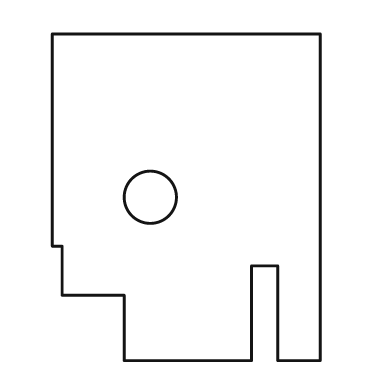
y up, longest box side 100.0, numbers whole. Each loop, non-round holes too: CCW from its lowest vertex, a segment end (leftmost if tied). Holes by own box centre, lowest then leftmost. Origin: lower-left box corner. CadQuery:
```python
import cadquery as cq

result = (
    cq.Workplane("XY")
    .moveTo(22.0, 0.0)
    .lineTo(61.0, 0.0)
    .lineTo(61.0, 29.0)
    .lineTo(69.0, 29.0)
    .lineTo(69.0, 0.0)
    .lineTo(82.0, 0.0)
    .lineTo(82.0, 100.0)
    .lineTo(0.0, 100.0)
    .lineTo(0.0, 35.0)
    .lineTo(3.0, 35.0)
    .lineTo(3.0, 20.0)
    .lineTo(22.0, 20.0)
    .close()
    .moveTo(30.0, 50.0)
    .circle(8.0)
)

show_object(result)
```